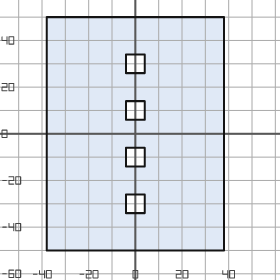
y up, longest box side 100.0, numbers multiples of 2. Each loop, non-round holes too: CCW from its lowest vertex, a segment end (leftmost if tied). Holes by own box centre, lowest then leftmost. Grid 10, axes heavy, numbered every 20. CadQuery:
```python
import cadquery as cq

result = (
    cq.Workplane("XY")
    .moveTo(-38.0, -50.0)
    .lineTo(38.0, -50.0)
    .lineTo(38.0, 50.0)
    .lineTo(-38.0, 50.0)
    .close()
    .moveTo(-4.0, -34.0)
    .lineTo(4.0, -34.0)
    .lineTo(4.0, -26.0)
    .lineTo(-4.0, -26.0)
    .close()
    .moveTo(-4.0, -14.0)
    .lineTo(4.0, -14.0)
    .lineTo(4.0, -6.0)
    .lineTo(-4.0, -6.0)
    .close()
    .moveTo(-4.0, 6.0)
    .lineTo(4.0, 6.0)
    .lineTo(4.0, 14.0)
    .lineTo(-4.0, 14.0)
    .close()
    .moveTo(-4.0, 26.0)
    .lineTo(4.0, 26.0)
    .lineTo(4.0, 34.0)
    .lineTo(-4.0, 34.0)
    .close()
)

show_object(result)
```